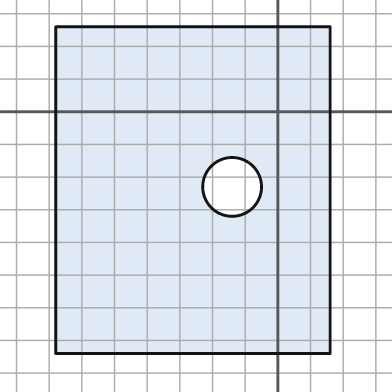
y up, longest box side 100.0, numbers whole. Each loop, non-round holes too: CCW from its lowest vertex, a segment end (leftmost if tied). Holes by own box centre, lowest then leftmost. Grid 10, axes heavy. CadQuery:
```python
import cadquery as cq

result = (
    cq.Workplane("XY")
    .moveTo(-68.0, -74.0)
    .lineTo(16.0, -74.0)
    .lineTo(16.0, 26.0)
    .lineTo(-68.0, 26.0)
    .close()
    .moveTo(-14.0, -23.0)
    .circle(9.0)
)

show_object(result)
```